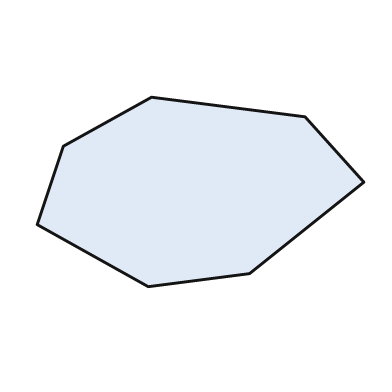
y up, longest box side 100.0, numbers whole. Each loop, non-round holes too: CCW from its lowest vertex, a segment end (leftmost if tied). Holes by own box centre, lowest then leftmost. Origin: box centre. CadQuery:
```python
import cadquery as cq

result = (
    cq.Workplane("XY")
    .moveTo(-16.0, -29.0)
    .lineTo(15.0, -25.0)
    .lineTo(50.0, 3.0)
    .lineTo(32.0, 23.0)
    .lineTo(-15.0, 29.0)
    .lineTo(-42.0, 14.0)
    .lineTo(-50.0, -10.0)
    .close()
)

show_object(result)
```